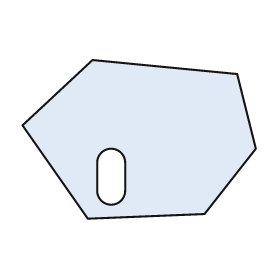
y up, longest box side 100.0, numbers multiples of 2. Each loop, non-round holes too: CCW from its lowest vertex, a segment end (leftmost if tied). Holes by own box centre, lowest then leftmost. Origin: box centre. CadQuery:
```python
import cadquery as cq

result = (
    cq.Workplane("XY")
    .moveTo(-22.0, -34.0)
    .lineTo(28.0, -32.0)
    .lineTo(50.0, -4.0)
    .lineTo(42.0, 28.0)
    .lineTo(-20.0, 34.0)
    .lineTo(-50.0, 6.0)
    .close()
    .moveTo(-18.0, -22.0)
    .threePointArc((-12.0, -28.0), (-6.0, -22.0))
    .lineTo(-6.0, -10.0)
    .threePointArc((-12.0, -4.0), (-18.0, -10.0))
    .close()
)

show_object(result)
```